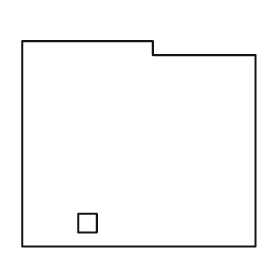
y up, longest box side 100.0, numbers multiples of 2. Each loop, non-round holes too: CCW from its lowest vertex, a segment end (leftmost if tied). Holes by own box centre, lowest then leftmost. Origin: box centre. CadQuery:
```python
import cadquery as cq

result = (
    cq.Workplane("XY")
    .moveTo(-50.0, -44.0)
    .lineTo(50.0, -44.0)
    .lineTo(50.0, 38.0)
    .lineTo(6.0, 38.0)
    .lineTo(6.0, 44.0)
    .lineTo(-50.0, 44.0)
    .close()
    .moveTo(-26.0, -38.0)
    .lineTo(-18.0, -38.0)
    .lineTo(-18.0, -30.0)
    .lineTo(-26.0, -30.0)
    .close()
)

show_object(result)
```